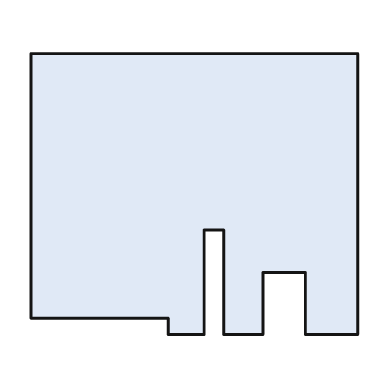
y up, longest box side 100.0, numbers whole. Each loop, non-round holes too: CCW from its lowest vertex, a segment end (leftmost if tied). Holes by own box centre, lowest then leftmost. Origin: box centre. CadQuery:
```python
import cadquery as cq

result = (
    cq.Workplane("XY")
    .moveTo(-8.0, -43.0)
    .lineTo(3.0, -43.0)
    .lineTo(3.0, -11.0)
    .lineTo(9.0, -11.0)
    .lineTo(9.0, -43.0)
    .lineTo(21.0, -43.0)
    .lineTo(21.0, -24.0)
    .lineTo(34.0, -24.0)
    .lineTo(34.0, -43.0)
    .lineTo(50.0, -43.0)
    .lineTo(50.0, 43.0)
    .lineTo(-50.0, 43.0)
    .lineTo(-50.0, -38.0)
    .lineTo(-8.0, -38.0)
    .close()
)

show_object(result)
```